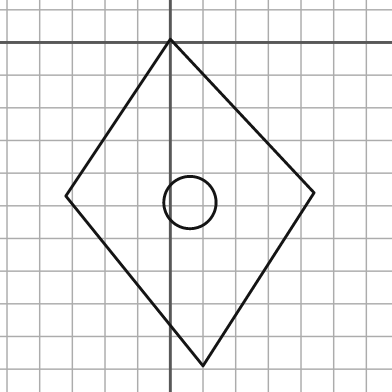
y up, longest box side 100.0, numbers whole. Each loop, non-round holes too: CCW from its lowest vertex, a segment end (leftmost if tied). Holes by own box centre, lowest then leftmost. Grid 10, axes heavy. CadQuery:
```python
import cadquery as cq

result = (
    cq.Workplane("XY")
    .moveTo(10.0, -99.0)
    .lineTo(44.0, -46.0)
    .lineTo(0.0, 1.0)
    .lineTo(-32.0, -47.0)
    .close()
    .moveTo(6.0, -49.0)
    .circle(8.0)
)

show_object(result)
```